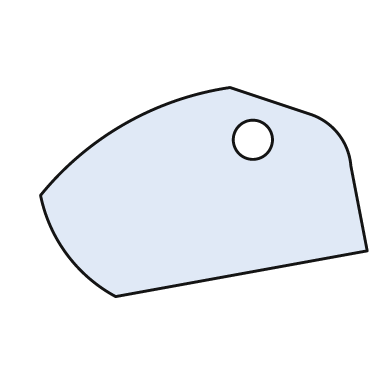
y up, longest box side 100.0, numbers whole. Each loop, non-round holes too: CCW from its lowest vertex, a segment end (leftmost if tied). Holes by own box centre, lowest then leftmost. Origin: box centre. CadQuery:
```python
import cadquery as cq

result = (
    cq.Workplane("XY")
    .moveTo(-27.0, -32.0)
    .lineTo(50.0, -18.0)
    .lineTo(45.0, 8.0)
    .threePointArc((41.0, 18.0), (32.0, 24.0))
    .lineTo(8.0, 32.0)
    .threePointArc((-24.0, 21.0), (-50.0, -1.0))
    .threePointArc((-42.0, -19.0), (-27.0, -32.0))
    .close()
    .moveTo(15.0, 16.0)
    .circle(6.0)
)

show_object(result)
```